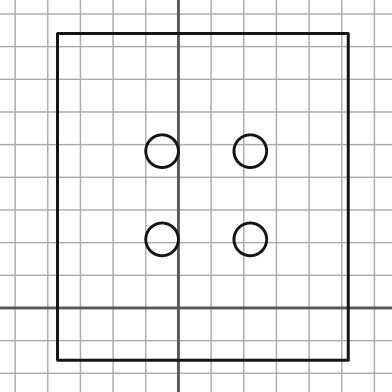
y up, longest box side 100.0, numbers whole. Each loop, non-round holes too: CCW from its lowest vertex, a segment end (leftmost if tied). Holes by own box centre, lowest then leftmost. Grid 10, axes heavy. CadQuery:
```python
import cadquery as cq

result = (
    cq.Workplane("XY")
    .moveTo(-37.0, -16.0)
    .lineTo(52.0, -16.0)
    .lineTo(52.0, 84.0)
    .lineTo(-37.0, 84.0)
    .close()
    .moveTo(-5.0, 21.0)
    .circle(5.0)
    .moveTo(22.0, 21.0)
    .circle(5.0)
    .moveTo(-5.0, 48.0)
    .circle(5.0)
    .moveTo(22.0, 48.0)
    .circle(5.0)
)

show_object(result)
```